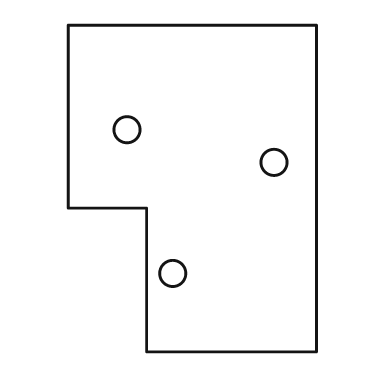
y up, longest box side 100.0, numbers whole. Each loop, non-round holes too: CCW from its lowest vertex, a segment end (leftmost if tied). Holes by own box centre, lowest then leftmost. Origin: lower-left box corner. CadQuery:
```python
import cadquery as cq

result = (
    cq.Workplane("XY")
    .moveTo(24.0, 0.0)
    .lineTo(76.0, 0.0)
    .lineTo(76.0, 100.0)
    .lineTo(0.0, 100.0)
    .lineTo(0.0, 44.0)
    .lineTo(24.0, 44.0)
    .close()
    .moveTo(32.0, 24.0)
    .circle(4.0)
    .moveTo(63.0, 58.0)
    .circle(4.0)
    .moveTo(18.0, 68.0)
    .circle(4.0)
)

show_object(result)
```